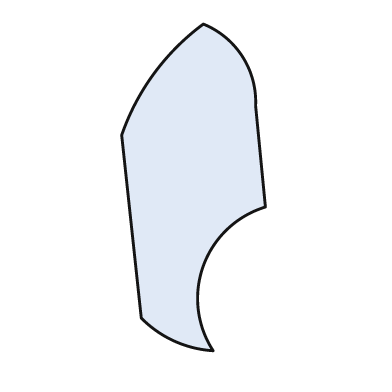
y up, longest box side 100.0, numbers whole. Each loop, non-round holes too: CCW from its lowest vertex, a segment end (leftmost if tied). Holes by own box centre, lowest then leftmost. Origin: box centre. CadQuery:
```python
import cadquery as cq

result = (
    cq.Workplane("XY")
    .moveTo(6.0, -50.0)
    .threePointArc((3.0, -24.0), (22.0, -6.0))
    .lineTo(19.0, 25.0)
    .threePointArc((15.0, 40.0), (3.0, 50.0))
    .threePointArc((-12.0, 35.0), (-22.0, 16.0))
    .lineTo(-16.0, -40.0)
    .threePointArc((-6.0, -47.0), (6.0, -50.0))
    .close()
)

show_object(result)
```